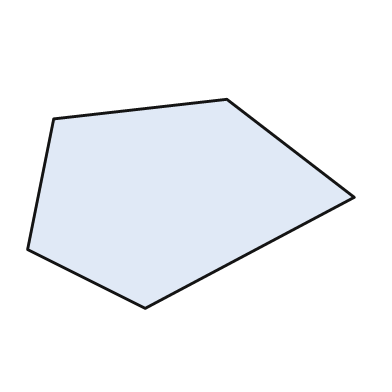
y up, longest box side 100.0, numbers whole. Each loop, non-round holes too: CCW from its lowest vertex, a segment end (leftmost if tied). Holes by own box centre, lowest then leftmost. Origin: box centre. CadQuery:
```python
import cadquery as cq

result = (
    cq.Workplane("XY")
    .moveTo(-14.0, -32.0)
    .lineTo(50.0, 2.0)
    .lineTo(11.0, 32.0)
    .lineTo(-42.0, 26.0)
    .lineTo(-50.0, -14.0)
    .close()
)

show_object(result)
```